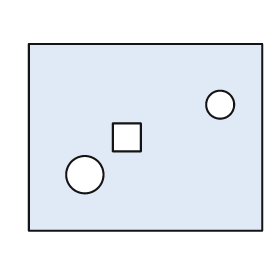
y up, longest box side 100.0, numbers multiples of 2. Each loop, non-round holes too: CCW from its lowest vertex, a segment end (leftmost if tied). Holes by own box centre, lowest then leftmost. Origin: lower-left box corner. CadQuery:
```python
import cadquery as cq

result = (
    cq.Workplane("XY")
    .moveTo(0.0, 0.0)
    .lineTo(100.0, 0.0)
    .lineTo(100.0, 80.0)
    .lineTo(0.0, 80.0)
    .close()
    .moveTo(24.0, 24.0)
    .circle(8.0)
    .moveTo(36.0, 34.0)
    .lineTo(48.0, 34.0)
    .lineTo(48.0, 46.0)
    .lineTo(36.0, 46.0)
    .close()
    .moveTo(82.0, 54.0)
    .circle(6.0)
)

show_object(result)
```